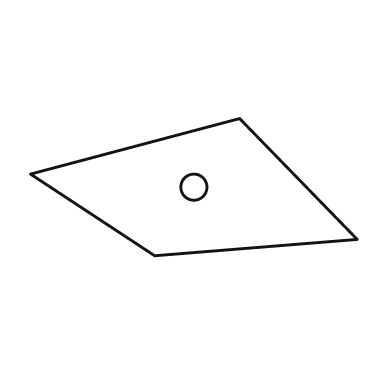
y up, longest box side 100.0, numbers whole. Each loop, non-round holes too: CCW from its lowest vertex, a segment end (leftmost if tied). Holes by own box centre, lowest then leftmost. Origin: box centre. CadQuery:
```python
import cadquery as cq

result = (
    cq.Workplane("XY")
    .moveTo(-12.0, -21.0)
    .lineTo(50.0, -16.0)
    .lineTo(14.0, 21.0)
    .lineTo(-50.0, 4.0)
    .close()
    .moveTo(0.0, 0.0)
    .circle(4.0)
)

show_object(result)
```